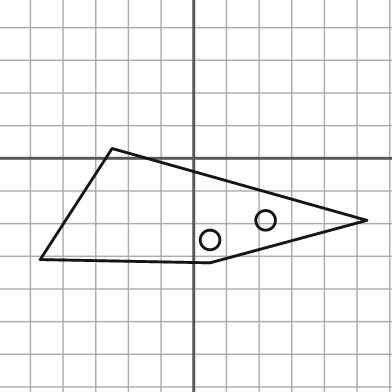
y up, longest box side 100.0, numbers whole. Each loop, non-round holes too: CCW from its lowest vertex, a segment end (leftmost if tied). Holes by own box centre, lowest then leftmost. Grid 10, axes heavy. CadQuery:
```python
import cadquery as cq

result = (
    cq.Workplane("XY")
    .moveTo(5.0, -32.0)
    .lineTo(53.0, -19.0)
    .lineTo(-25.0, 3.0)
    .lineTo(-47.0, -31.0)
    .close()
    .moveTo(5.0, -25.0)
    .circle(3.0)
    .moveTo(22.0, -19.0)
    .circle(3.0)
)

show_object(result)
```